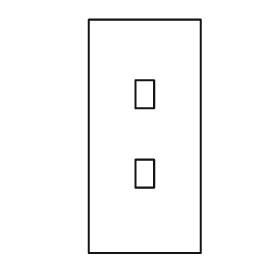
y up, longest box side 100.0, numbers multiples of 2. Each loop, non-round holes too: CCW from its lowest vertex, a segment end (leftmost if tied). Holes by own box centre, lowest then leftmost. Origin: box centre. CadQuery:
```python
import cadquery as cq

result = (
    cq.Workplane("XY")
    .moveTo(-24.0, -50.0)
    .lineTo(24.0, -50.0)
    .lineTo(24.0, 50.0)
    .lineTo(-24.0, 50.0)
    .close()
    .moveTo(-4.0, -22.0)
    .lineTo(4.0, -22.0)
    .lineTo(4.0, -10.0)
    .lineTo(-4.0, -10.0)
    .close()
    .moveTo(-4.0, 12.0)
    .lineTo(4.0, 12.0)
    .lineTo(4.0, 24.0)
    .lineTo(-4.0, 24.0)
    .close()
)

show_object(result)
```